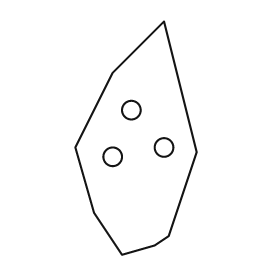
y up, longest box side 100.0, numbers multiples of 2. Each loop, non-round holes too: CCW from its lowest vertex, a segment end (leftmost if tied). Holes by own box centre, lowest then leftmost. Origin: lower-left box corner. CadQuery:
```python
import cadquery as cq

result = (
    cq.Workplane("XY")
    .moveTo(20.0, 0.0)
    .lineTo(34.0, 4.0)
    .lineTo(40.0, 8.0)
    .lineTo(52.0, 44.0)
    .lineTo(38.0, 100.0)
    .lineTo(16.0, 78.0)
    .lineTo(0.0, 46.0)
    .lineTo(8.0, 18.0)
    .close()
    .moveTo(16.0, 42.0)
    .circle(4.0)
    .moveTo(38.0, 46.0)
    .circle(4.0)
    .moveTo(24.0, 62.0)
    .circle(4.0)
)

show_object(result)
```